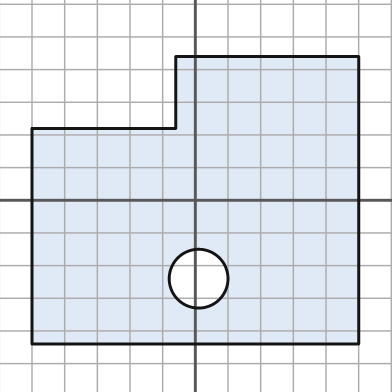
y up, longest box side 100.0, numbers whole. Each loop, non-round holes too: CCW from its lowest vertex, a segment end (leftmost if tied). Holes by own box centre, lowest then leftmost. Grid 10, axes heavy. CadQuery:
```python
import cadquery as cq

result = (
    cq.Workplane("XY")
    .moveTo(-50.0, -44.0)
    .lineTo(50.0, -44.0)
    .lineTo(50.0, 44.0)
    .lineTo(-6.0, 44.0)
    .lineTo(-6.0, 22.0)
    .lineTo(-50.0, 22.0)
    .close()
    .moveTo(1.0, -24.0)
    .circle(9.0)
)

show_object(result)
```